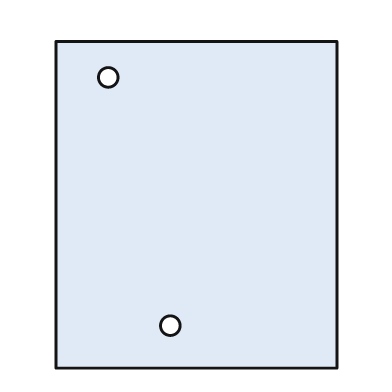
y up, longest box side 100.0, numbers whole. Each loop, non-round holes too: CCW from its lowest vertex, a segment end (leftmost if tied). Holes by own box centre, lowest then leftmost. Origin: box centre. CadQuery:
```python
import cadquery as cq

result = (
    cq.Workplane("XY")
    .moveTo(-43.0, -50.0)
    .lineTo(43.0, -50.0)
    .lineTo(43.0, 50.0)
    .lineTo(-43.0, 50.0)
    .close()
    .moveTo(-8.0, -37.0)
    .circle(3.0)
    .moveTo(-27.0, 39.0)
    .circle(3.0)
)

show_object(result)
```